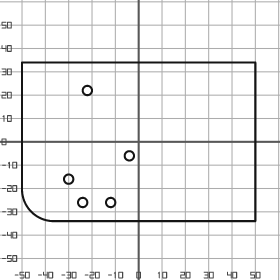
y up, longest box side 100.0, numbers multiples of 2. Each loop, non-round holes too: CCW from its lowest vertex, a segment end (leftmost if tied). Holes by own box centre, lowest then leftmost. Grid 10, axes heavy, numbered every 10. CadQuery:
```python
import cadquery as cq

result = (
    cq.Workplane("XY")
    .moveTo(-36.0, -34.0)
    .lineTo(50.0, -34.0)
    .lineTo(50.0, 34.0)
    .lineTo(-50.0, 34.0)
    .lineTo(-50.0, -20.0)
    .threePointArc((-46.0, -30.0), (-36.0, -34.0))
    .close()
    .moveTo(-24.0, -26.0)
    .circle(2.0)
    .moveTo(-12.0, -26.0)
    .circle(2.0)
    .moveTo(-30.0, -16.0)
    .circle(2.0)
    .moveTo(-4.0, -6.0)
    .circle(2.0)
    .moveTo(-22.0, 22.0)
    .circle(2.0)
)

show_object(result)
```